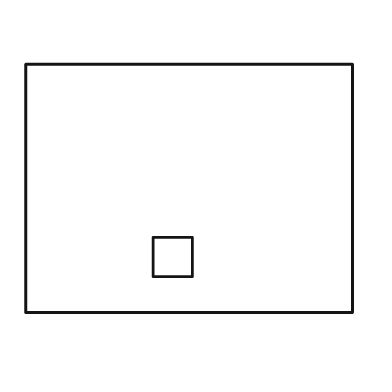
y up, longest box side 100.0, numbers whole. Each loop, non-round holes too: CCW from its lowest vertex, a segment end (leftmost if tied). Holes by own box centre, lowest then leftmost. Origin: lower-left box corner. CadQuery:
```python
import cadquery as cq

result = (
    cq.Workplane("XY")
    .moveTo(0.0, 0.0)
    .lineTo(100.0, 0.0)
    .lineTo(100.0, 76.0)
    .lineTo(0.0, 76.0)
    .close()
    .moveTo(39.0, 11.0)
    .lineTo(51.0, 11.0)
    .lineTo(51.0, 23.0)
    .lineTo(39.0, 23.0)
    .close()
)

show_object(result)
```